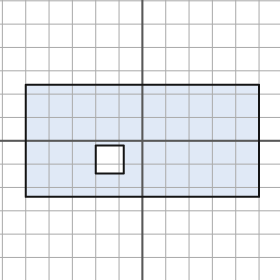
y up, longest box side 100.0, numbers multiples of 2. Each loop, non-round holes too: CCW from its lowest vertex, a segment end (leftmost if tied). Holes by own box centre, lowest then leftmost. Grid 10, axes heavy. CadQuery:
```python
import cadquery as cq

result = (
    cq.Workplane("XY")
    .moveTo(-50.0, -24.0)
    .lineTo(50.0, -24.0)
    .lineTo(50.0, 24.0)
    .lineTo(-50.0, 24.0)
    .close()
    .moveTo(-20.0, -14.0)
    .lineTo(-8.0, -14.0)
    .lineTo(-8.0, -2.0)
    .lineTo(-20.0, -2.0)
    .close()
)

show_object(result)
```